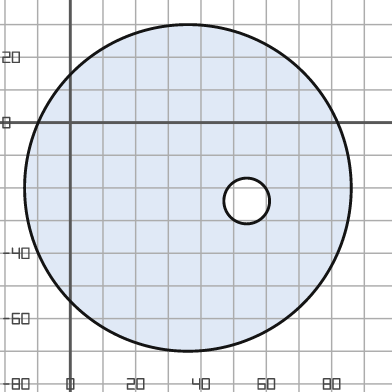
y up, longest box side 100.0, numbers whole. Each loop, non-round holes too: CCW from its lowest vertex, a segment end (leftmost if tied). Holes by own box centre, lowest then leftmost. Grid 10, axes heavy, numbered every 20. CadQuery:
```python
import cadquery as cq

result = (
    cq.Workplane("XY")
    .moveTo(36.0, -20.0)
    .circle(50.0)
    .moveTo(54.0, -24.0)
    .circle(7.0)
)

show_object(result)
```